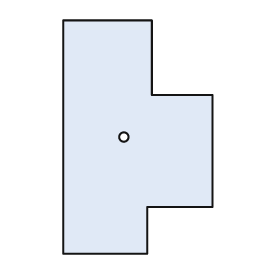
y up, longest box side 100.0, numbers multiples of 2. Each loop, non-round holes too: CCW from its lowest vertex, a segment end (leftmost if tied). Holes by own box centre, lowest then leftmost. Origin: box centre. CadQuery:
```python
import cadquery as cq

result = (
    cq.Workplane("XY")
    .moveTo(-32.0, -50.0)
    .lineTo(4.0, -50.0)
    .lineTo(4.0, -30.0)
    .lineTo(32.0, -30.0)
    .lineTo(32.0, 18.0)
    .lineTo(6.0, 18.0)
    .lineTo(6.0, 50.0)
    .lineTo(-32.0, 50.0)
    .close()
    .moveTo(-6.0, 0.0)
    .circle(2.0)
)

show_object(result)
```